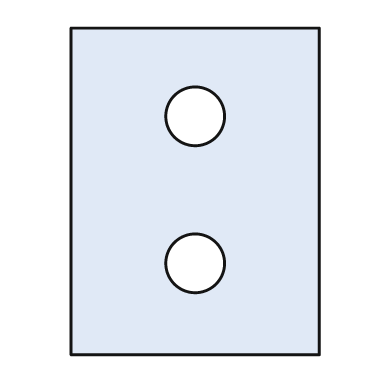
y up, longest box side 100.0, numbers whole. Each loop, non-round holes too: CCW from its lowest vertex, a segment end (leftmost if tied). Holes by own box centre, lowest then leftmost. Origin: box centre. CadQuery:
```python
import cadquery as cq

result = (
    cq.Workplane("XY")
    .moveTo(-38.0, -50.0)
    .lineTo(38.0, -50.0)
    .lineTo(38.0, 50.0)
    .lineTo(-38.0, 50.0)
    .close()
    .moveTo(0.0, -22.0)
    .circle(9.0)
    .moveTo(0.0, 23.0)
    .circle(9.0)
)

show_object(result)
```